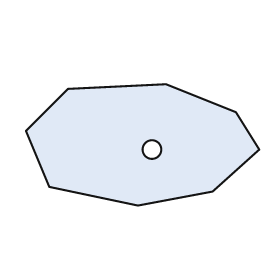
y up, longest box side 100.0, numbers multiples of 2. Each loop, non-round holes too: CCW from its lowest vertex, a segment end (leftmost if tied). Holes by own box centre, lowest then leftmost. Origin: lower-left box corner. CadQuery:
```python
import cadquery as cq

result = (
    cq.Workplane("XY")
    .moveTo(48.0, 0.0)
    .lineTo(80.0, 6.0)
    .lineTo(100.0, 24.0)
    .lineTo(90.0, 40.0)
    .lineTo(60.0, 52.0)
    .lineTo(18.0, 50.0)
    .lineTo(0.0, 32.0)
    .lineTo(10.0, 8.0)
    .close()
    .moveTo(54.0, 24.0)
    .circle(4.0)
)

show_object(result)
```